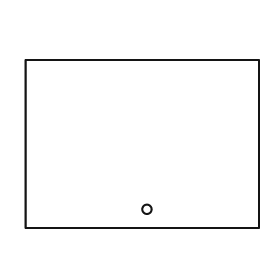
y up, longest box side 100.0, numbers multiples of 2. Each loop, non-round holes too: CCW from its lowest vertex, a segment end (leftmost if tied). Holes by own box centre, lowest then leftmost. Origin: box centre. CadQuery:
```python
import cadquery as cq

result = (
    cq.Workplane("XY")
    .moveTo(-50.0, -36.0)
    .lineTo(50.0, -36.0)
    .lineTo(50.0, 36.0)
    .lineTo(-50.0, 36.0)
    .close()
    .moveTo(2.0, -28.0)
    .circle(2.0)
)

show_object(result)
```